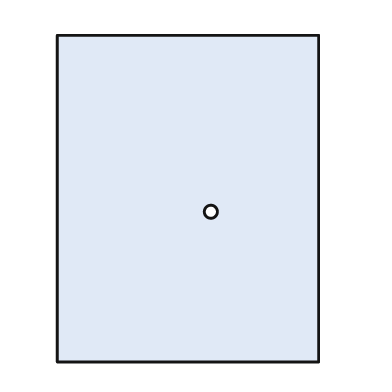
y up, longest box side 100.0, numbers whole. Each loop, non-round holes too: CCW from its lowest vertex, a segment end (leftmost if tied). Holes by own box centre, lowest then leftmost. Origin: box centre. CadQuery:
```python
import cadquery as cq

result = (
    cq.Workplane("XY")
    .moveTo(-40.0, -50.0)
    .lineTo(40.0, -50.0)
    .lineTo(40.0, 50.0)
    .lineTo(-40.0, 50.0)
    .close()
    .moveTo(7.0, -4.0)
    .circle(2.0)
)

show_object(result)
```